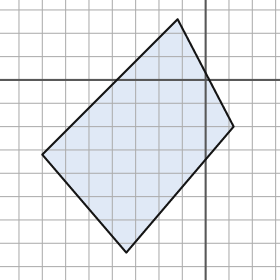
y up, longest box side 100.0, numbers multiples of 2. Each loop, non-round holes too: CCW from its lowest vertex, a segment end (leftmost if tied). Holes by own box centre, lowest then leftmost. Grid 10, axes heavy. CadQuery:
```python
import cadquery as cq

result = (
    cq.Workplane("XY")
    .moveTo(-34.0, -74.0)
    .lineTo(12.0, -20.0)
    .lineTo(-12.0, 26.0)
    .lineTo(-70.0, -32.0)
    .close()
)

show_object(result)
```